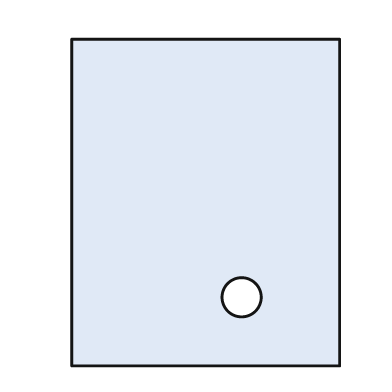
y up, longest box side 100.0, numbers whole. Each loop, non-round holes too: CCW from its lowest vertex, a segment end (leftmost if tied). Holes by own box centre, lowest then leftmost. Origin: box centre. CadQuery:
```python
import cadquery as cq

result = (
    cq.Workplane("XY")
    .moveTo(-41.0, -50.0)
    .lineTo(41.0, -50.0)
    .lineTo(41.0, 50.0)
    .lineTo(-41.0, 50.0)
    .close()
    .moveTo(11.0, -29.0)
    .circle(6.0)
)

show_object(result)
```